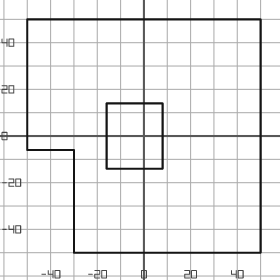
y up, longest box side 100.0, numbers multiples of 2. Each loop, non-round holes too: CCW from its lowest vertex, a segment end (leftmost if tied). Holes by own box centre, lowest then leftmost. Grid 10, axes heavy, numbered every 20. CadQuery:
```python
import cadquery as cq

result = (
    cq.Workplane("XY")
    .moveTo(-30.0, -50.0)
    .lineTo(50.0, -50.0)
    .lineTo(50.0, 50.0)
    .lineTo(-50.0, 50.0)
    .lineTo(-50.0, -6.0)
    .lineTo(-30.0, -6.0)
    .close()
    .moveTo(-16.0, -14.0)
    .lineTo(8.0, -14.0)
    .lineTo(8.0, 14.0)
    .lineTo(-16.0, 14.0)
    .close()
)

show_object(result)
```